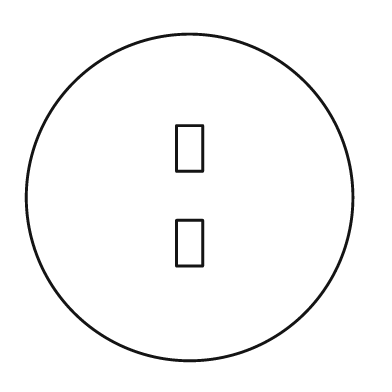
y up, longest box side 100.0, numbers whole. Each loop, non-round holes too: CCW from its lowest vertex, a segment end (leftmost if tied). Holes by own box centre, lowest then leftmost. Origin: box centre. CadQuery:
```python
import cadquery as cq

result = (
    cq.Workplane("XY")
    .moveTo(0.0, 0.0)
    .circle(50.0)
    .moveTo(-4.0, -21.0)
    .lineTo(4.0, -21.0)
    .lineTo(4.0, -7.0)
    .lineTo(-4.0, -7.0)
    .close()
    .moveTo(-4.0, 8.0)
    .lineTo(4.0, 8.0)
    .lineTo(4.0, 22.0)
    .lineTo(-4.0, 22.0)
    .close()
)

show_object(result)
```